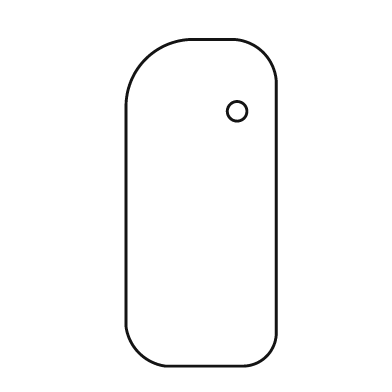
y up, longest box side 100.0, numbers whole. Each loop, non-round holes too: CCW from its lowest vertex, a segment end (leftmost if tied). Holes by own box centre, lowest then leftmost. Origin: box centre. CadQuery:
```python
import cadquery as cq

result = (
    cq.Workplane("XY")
    .moveTo(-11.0, -50.0)
    .lineTo(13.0, -50.0)
    .threePointArc((20.0, -47.0), (23.0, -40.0))
    .lineTo(23.0, 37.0)
    .threePointArc((19.0, 46.0), (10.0, 50.0))
    .lineTo(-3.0, 50.0)
    .threePointArc((-17.0, 44.0), (-23.0, 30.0))
    .lineTo(-23.0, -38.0)
    .threePointArc((-19.0, -46.0), (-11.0, -50.0))
    .close()
    .moveTo(11.0, 28.0)
    .circle(3.0)
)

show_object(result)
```